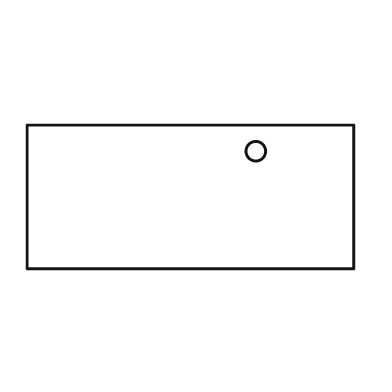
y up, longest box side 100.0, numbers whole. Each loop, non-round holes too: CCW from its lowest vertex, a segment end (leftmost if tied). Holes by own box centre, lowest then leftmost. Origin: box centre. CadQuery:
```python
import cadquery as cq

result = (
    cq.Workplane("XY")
    .moveTo(-50.0, -22.0)
    .lineTo(50.0, -22.0)
    .lineTo(50.0, 22.0)
    .lineTo(-50.0, 22.0)
    .close()
    .moveTo(20.0, 14.0)
    .circle(3.0)
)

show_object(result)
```